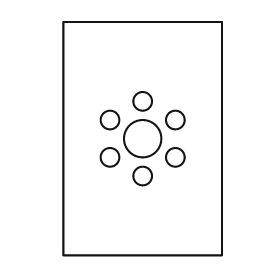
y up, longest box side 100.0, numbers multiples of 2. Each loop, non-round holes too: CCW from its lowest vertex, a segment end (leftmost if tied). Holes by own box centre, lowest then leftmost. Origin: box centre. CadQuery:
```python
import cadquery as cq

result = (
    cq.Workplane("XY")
    .moveTo(-34.0, -50.0)
    .lineTo(34.0, -50.0)
    .lineTo(34.0, 50.0)
    .lineTo(-34.0, 50.0)
    .close()
    .moveTo(0.0, -16.0)
    .circle(4.0)
    .moveTo(-14.0, -8.0)
    .circle(4.0)
    .moveTo(14.0, -8.0)
    .circle(4.0)
    .moveTo(0.0, 0.0)
    .circle(8.0)
    .moveTo(-14.0, 8.0)
    .circle(4.0)
    .moveTo(14.0, 8.0)
    .circle(4.0)
    .moveTo(0.0, 16.0)
    .circle(4.0)
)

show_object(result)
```